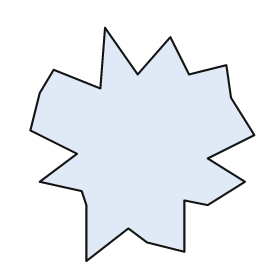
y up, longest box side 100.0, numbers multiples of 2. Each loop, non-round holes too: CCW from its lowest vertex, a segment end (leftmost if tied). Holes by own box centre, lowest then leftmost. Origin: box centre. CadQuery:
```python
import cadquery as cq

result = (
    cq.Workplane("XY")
    .moveTo(-24.0, -50.0)
    .lineTo(-6.0, -36.0)
    .lineTo(2.0, -42.0)
    .lineTo(18.0, -46.0)
    .lineTo(18.0, -24.0)
    .lineTo(28.0, -26.0)
    .lineTo(44.0, -16.0)
    .lineTo(28.0, -6.0)
    .lineTo(48.0, 4.0)
    .lineTo(38.0, 20.0)
    .lineTo(36.0, 34.0)
    .lineTo(20.0, 30.0)
    .lineTo(12.0, 46.0)
    .lineTo(-2.0, 30.0)
    .lineTo(-16.0, 50.0)
    .lineTo(-18.0, 24.0)
    .lineTo(-38.0, 32.0)
    .lineTo(-44.0, 22.0)
    .lineTo(-48.0, 6.0)
    .lineTo(-28.0, -4.0)
    .lineTo(-44.0, -16.0)
    .lineTo(-26.0, -20.0)
    .lineTo(-24.0, -26.0)
    .close()
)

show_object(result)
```